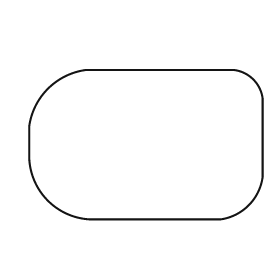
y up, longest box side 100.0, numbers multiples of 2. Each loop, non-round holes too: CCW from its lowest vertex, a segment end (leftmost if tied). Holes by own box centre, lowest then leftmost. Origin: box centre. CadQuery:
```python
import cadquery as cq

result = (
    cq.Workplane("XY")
    .moveTo(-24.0, -32.0)
    .lineTo(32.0, -32.0)
    .threePointArc((44.0, -26.0), (50.0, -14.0))
    .lineTo(50.0, 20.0)
    .threePointArc((46.0, 28.0), (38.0, 32.0))
    .lineTo(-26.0, 32.0)
    .threePointArc((-42.0, 24.0), (-50.0, 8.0))
    .lineTo(-50.0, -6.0)
    .threePointArc((-42.0, -24.0), (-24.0, -32.0))
    .close()
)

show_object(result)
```